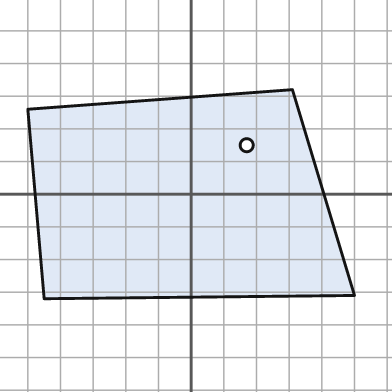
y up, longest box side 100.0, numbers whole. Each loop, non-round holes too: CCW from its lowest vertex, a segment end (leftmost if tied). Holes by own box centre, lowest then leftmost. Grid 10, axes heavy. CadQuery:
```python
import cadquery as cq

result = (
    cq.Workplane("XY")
    .moveTo(-45.0, -32.0)
    .lineTo(50.0, -31.0)
    .lineTo(31.0, 32.0)
    .lineTo(-50.0, 26.0)
    .close()
    .moveTo(17.0, 15.0)
    .circle(2.0)
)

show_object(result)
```